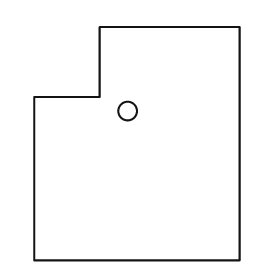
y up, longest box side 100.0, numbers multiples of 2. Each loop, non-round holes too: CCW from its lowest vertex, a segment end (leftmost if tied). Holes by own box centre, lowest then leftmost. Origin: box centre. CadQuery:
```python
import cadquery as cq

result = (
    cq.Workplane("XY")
    .moveTo(-44.0, -50.0)
    .lineTo(44.0, -50.0)
    .lineTo(44.0, 50.0)
    .lineTo(-16.0, 50.0)
    .lineTo(-16.0, 20.0)
    .lineTo(-44.0, 20.0)
    .close()
    .moveTo(-4.0, 14.0)
    .circle(4.0)
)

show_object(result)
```